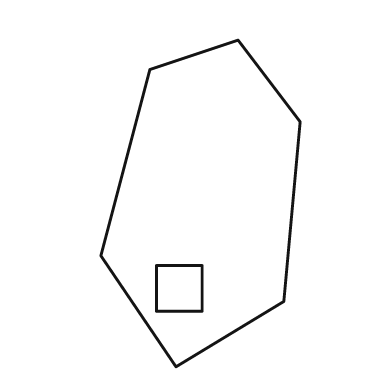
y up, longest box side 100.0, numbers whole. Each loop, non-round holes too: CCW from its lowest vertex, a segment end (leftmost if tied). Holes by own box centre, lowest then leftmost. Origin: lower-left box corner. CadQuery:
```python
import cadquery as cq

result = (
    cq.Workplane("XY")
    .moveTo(23.0, 0.0)
    .lineTo(56.0, 20.0)
    .lineTo(61.0, 75.0)
    .lineTo(42.0, 100.0)
    .lineTo(15.0, 91.0)
    .lineTo(0.0, 34.0)
    .close()
    .moveTo(17.0, 17.0)
    .lineTo(31.0, 17.0)
    .lineTo(31.0, 31.0)
    .lineTo(17.0, 31.0)
    .close()
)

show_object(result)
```